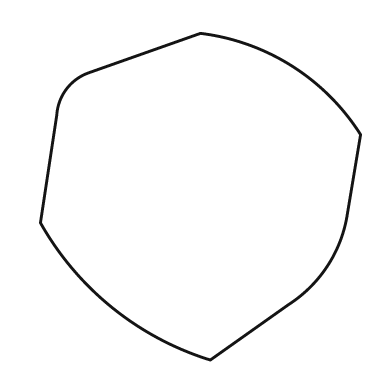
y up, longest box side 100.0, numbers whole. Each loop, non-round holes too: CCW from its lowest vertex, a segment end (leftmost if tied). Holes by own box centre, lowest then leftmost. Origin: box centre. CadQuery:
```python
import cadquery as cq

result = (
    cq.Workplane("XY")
    .moveTo(3.0, -50.0)
    .lineTo(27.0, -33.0)
    .threePointArc((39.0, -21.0), (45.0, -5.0))
    .lineTo(49.0, 19.0)
    .threePointArc((28.0, 40.0), (0.0, 50.0))
    .lineTo(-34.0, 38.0)
    .threePointArc((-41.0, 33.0), (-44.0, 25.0))
    .lineTo(-49.0, -8.0)
    .threePointArc((-27.0, -34.0), (3.0, -50.0))
    .close()
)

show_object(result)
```